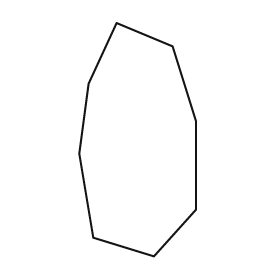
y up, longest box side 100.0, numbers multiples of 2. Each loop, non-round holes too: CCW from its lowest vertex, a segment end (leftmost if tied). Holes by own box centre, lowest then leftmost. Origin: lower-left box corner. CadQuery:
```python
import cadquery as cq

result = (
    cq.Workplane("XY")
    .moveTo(32.0, 0.0)
    .lineTo(50.0, 20.0)
    .lineTo(50.0, 58.0)
    .lineTo(40.0, 90.0)
    .lineTo(16.0, 100.0)
    .lineTo(4.0, 74.0)
    .lineTo(0.0, 44.0)
    .lineTo(6.0, 8.0)
    .close()
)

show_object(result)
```